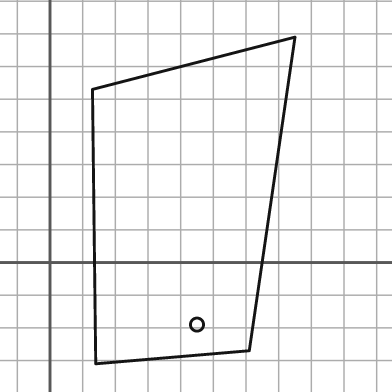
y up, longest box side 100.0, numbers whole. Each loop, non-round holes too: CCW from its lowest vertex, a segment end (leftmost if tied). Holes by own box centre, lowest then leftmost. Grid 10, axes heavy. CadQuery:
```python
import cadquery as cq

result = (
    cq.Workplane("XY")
    .moveTo(14.0, -31.0)
    .lineTo(61.0, -27.0)
    .lineTo(75.0, 69.0)
    .lineTo(13.0, 53.0)
    .close()
    .moveTo(45.0, -19.0)
    .circle(2.0)
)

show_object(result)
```